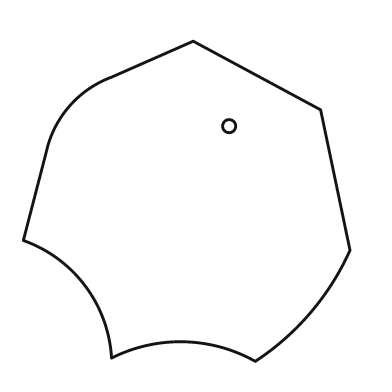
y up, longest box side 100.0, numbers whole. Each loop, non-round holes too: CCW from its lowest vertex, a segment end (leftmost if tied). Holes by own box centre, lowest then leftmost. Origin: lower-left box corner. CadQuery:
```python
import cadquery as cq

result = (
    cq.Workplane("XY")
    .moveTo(71.0, 0.0)
    .threePointArc((88.0, 15.0), (100.0, 34.0))
    .lineTo(91.0, 77.0)
    .lineTo(52.0, 98.0)
    .lineTo(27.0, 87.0)
    .threePointArc((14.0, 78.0), (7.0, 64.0))
    .lineTo(0.0, 37.0)
    .threePointArc((19.0, 23.0), (27.0, 1.0))
    .threePointArc((49.0, 6.0), (71.0, 0.0))
    .close()
    .moveTo(63.0, 72.0)
    .circle(2.0)
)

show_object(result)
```